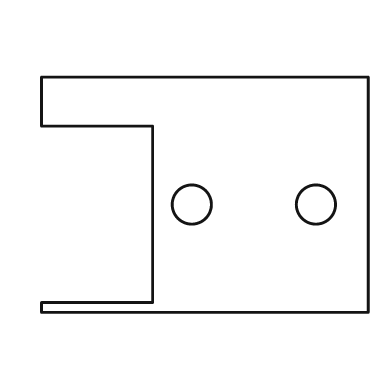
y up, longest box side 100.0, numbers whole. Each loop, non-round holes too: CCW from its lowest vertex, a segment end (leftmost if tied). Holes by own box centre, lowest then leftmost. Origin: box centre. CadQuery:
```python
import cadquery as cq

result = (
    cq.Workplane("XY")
    .moveTo(-50.0, -36.0)
    .lineTo(50.0, -36.0)
    .lineTo(50.0, 36.0)
    .lineTo(-50.0, 36.0)
    .lineTo(-50.0, 21.0)
    .lineTo(-16.0, 21.0)
    .lineTo(-16.0, -33.0)
    .lineTo(-50.0, -33.0)
    .close()
    .moveTo(-4.0, -3.0)
    .circle(6.0)
    .moveTo(34.0, -3.0)
    .circle(6.0)
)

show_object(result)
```